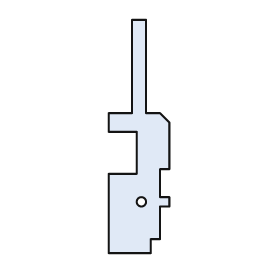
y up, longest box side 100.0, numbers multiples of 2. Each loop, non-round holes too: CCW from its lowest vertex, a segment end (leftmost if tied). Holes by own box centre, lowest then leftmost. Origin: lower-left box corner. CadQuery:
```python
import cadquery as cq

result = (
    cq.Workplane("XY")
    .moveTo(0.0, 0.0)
    .lineTo(18.0, 0.0)
    .lineTo(18.0, 6.0)
    .lineTo(22.0, 6.0)
    .lineTo(22.0, 20.0)
    .lineTo(26.0, 20.0)
    .lineTo(26.0, 24.0)
    .lineTo(22.0, 24.0)
    .lineTo(22.0, 36.0)
    .lineTo(26.0, 36.0)
    .lineTo(26.0, 56.0)
    .lineTo(22.0, 60.0)
    .lineTo(16.0, 60.0)
    .lineTo(16.0, 100.0)
    .lineTo(10.0, 100.0)
    .lineTo(10.0, 60.0)
    .lineTo(0.0, 60.0)
    .lineTo(0.0, 52.0)
    .lineTo(12.0, 52.0)
    .lineTo(12.0, 34.0)
    .lineTo(0.0, 34.0)
    .close()
    .moveTo(14.0, 22.0)
    .circle(2.0)
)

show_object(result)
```